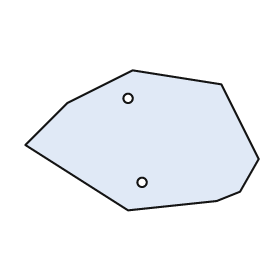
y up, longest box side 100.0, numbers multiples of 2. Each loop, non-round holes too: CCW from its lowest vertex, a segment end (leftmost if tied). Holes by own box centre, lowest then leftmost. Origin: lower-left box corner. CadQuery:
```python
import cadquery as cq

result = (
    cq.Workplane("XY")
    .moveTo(44.0, 0.0)
    .lineTo(82.0, 4.0)
    .lineTo(92.0, 8.0)
    .lineTo(100.0, 22.0)
    .lineTo(84.0, 54.0)
    .lineTo(46.0, 60.0)
    .lineTo(18.0, 46.0)
    .lineTo(0.0, 28.0)
    .close()
    .moveTo(50.0, 12.0)
    .circle(2.0)
    .moveTo(44.0, 48.0)
    .circle(2.0)
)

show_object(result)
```